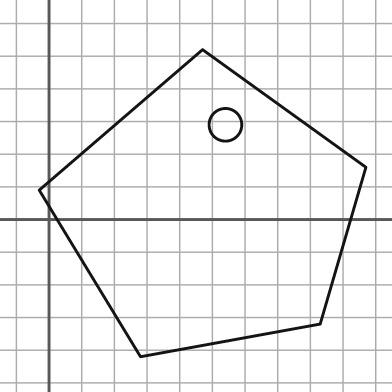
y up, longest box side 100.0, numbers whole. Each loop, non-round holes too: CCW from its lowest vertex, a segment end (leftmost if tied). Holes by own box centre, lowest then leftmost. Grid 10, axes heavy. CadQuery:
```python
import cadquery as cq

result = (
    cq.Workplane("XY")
    .moveTo(28.0, -42.0)
    .lineTo(83.0, -32.0)
    .lineTo(97.0, 16.0)
    .lineTo(47.0, 52.0)
    .lineTo(-3.0, 9.0)
    .close()
    .moveTo(54.0, 29.0)
    .circle(5.0)
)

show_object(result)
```